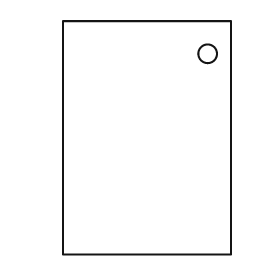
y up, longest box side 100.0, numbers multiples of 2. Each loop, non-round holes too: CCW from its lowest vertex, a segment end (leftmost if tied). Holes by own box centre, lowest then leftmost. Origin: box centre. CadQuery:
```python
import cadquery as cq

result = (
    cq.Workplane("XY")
    .moveTo(-36.0, -50.0)
    .lineTo(36.0, -50.0)
    .lineTo(36.0, 50.0)
    .lineTo(-36.0, 50.0)
    .close()
    .moveTo(26.0, 36.0)
    .circle(4.0)
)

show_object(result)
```